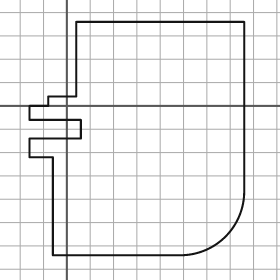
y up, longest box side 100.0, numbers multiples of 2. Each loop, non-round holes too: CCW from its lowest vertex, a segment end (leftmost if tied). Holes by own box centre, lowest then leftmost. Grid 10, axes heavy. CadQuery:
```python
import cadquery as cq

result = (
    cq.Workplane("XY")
    .moveTo(-6.0, -64.0)
    .lineTo(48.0, -64.0)
    .threePointArc((68.0, -56.0), (76.0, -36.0))
    .lineTo(76.0, 36.0)
    .lineTo(4.0, 36.0)
    .lineTo(4.0, 4.0)
    .lineTo(-8.0, 4.0)
    .lineTo(-8.0, 0.0)
    .lineTo(-16.0, 0.0)
    .lineTo(-16.0, -6.0)
    .lineTo(6.0, -6.0)
    .lineTo(6.0, -14.0)
    .lineTo(-16.0, -14.0)
    .lineTo(-16.0, -22.0)
    .lineTo(-6.0, -22.0)
    .close()
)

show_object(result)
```